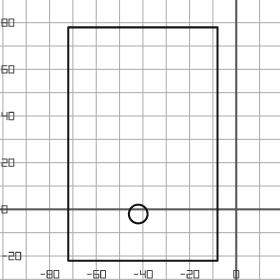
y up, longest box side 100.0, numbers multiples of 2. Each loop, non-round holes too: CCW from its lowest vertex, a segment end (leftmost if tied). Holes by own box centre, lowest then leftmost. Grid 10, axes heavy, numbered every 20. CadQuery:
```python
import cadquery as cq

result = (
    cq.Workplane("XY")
    .moveTo(-72.0, -22.0)
    .lineTo(-8.0, -22.0)
    .lineTo(-8.0, 78.0)
    .lineTo(-72.0, 78.0)
    .close()
    .moveTo(-42.0, -2.0)
    .circle(4.0)
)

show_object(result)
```